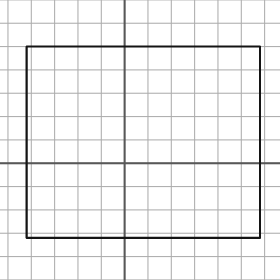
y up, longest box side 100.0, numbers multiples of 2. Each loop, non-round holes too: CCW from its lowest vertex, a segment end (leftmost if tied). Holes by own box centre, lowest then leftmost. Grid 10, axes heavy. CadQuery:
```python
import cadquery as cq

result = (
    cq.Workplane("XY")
    .moveTo(-42.0, -32.0)
    .lineTo(58.0, -32.0)
    .lineTo(58.0, 50.0)
    .lineTo(-42.0, 50.0)
    .close()
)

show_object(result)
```